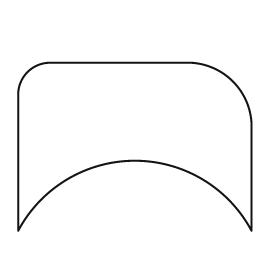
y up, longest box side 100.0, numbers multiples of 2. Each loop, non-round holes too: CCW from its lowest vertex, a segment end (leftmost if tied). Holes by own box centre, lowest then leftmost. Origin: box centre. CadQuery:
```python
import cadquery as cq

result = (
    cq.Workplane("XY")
    .moveTo(-50.0, -36.0)
    .threePointArc((0.0, -6.0), (50.0, -36.0))
    .lineTo(50.0, 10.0)
    .threePointArc((42.0, 28.0), (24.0, 36.0))
    .lineTo(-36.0, 36.0)
    .threePointArc((-46.0, 32.0), (-50.0, 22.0))
    .close()
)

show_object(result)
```